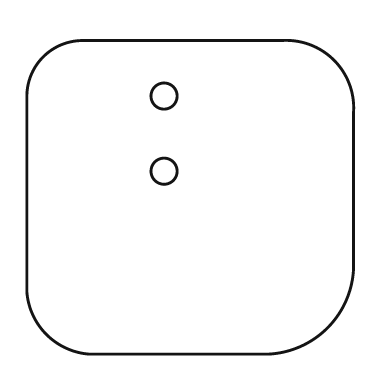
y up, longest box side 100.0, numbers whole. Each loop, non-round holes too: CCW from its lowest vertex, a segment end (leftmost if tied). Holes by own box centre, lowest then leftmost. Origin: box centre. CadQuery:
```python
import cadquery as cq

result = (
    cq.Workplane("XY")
    .moveTo(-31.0, -48.0)
    .lineTo(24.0, -48.0)
    .threePointArc((42.0, -40.0), (50.0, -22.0))
    .lineTo(50.0, 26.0)
    .threePointArc((44.0, 42.0), (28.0, 48.0))
    .lineTo(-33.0, 48.0)
    .threePointArc((-45.0, 43.0), (-50.0, 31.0))
    .lineTo(-50.0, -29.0)
    .threePointArc((-44.0, -42.0), (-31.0, -48.0))
    .close()
    .moveTo(-8.0, 8.0)
    .circle(4.0)
    .moveTo(-8.0, 31.0)
    .circle(4.0)
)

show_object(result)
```